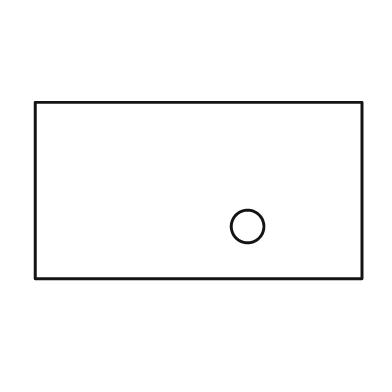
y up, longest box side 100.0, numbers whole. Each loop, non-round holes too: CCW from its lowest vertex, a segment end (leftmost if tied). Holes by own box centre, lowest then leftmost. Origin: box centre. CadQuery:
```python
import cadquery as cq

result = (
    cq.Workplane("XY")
    .moveTo(-50.0, -27.0)
    .lineTo(50.0, -27.0)
    .lineTo(50.0, 27.0)
    .lineTo(-50.0, 27.0)
    .close()
    .moveTo(15.0, -11.0)
    .circle(5.0)
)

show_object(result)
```